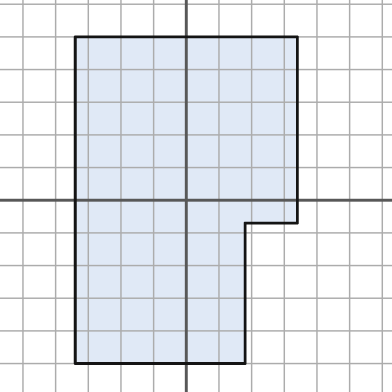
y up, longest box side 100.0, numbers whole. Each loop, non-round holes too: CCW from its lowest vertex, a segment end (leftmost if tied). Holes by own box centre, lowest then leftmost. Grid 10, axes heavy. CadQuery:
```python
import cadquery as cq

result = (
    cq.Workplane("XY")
    .moveTo(-34.0, -50.0)
    .lineTo(18.0, -50.0)
    .lineTo(18.0, -7.0)
    .lineTo(34.0, -7.0)
    .lineTo(34.0, 50.0)
    .lineTo(-34.0, 50.0)
    .close()
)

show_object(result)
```